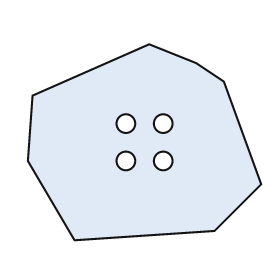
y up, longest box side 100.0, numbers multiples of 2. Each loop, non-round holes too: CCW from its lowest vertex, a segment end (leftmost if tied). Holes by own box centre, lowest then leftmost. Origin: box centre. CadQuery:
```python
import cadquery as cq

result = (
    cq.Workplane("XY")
    .moveTo(-30.0, -42.0)
    .lineTo(30.0, -38.0)
    .lineTo(50.0, -18.0)
    .lineTo(34.0, 26.0)
    .lineTo(22.0, 34.0)
    .lineTo(2.0, 42.0)
    .lineTo(-48.0, 20.0)
    .lineTo(-50.0, -8.0)
    .close()
    .moveTo(-8.0, -8.0)
    .circle(4.0)
    .moveTo(8.0, -8.0)
    .circle(4.0)
    .moveTo(-8.0, 8.0)
    .circle(4.0)
    .moveTo(8.0, 8.0)
    .circle(4.0)
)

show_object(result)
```